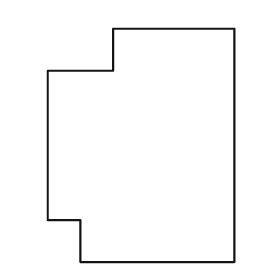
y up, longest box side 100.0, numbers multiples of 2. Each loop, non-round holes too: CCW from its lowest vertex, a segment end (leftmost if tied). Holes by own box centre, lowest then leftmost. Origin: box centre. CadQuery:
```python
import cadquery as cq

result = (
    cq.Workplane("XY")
    .moveTo(-26.0, -50.0)
    .lineTo(40.0, -50.0)
    .lineTo(40.0, 50.0)
    .lineTo(-12.0, 50.0)
    .lineTo(-12.0, 32.0)
    .lineTo(-40.0, 32.0)
    .lineTo(-40.0, -32.0)
    .lineTo(-26.0, -32.0)
    .close()
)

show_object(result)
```